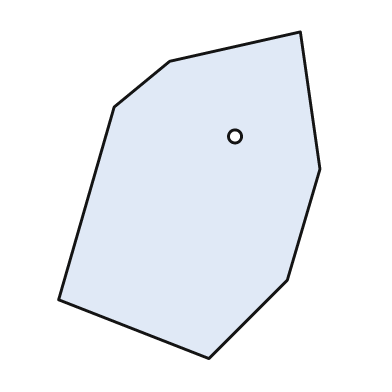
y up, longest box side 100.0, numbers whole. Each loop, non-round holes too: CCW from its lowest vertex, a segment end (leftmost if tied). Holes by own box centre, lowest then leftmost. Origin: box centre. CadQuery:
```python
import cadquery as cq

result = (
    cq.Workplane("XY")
    .moveTo(6.0, -50.0)
    .lineTo(30.0, -26.0)
    .lineTo(40.0, 8.0)
    .lineTo(34.0, 50.0)
    .lineTo(-6.0, 41.0)
    .lineTo(-23.0, 27.0)
    .lineTo(-40.0, -32.0)
    .close()
    .moveTo(14.0, 18.0)
    .circle(2.0)
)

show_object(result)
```